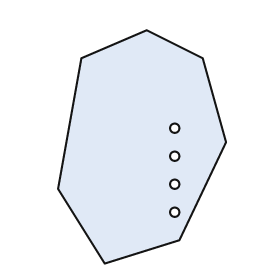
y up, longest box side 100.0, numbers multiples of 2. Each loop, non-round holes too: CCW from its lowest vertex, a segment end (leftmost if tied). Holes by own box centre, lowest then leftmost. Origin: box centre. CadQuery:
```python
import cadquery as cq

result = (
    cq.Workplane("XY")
    .moveTo(-16.0, -50.0)
    .lineTo(16.0, -40.0)
    .lineTo(36.0, 2.0)
    .lineTo(26.0, 38.0)
    .lineTo(2.0, 50.0)
    .lineTo(-26.0, 38.0)
    .lineTo(-36.0, -18.0)
    .close()
    .moveTo(14.0, -28.0)
    .circle(2.0)
    .moveTo(14.0, -16.0)
    .circle(2.0)
    .moveTo(14.0, -4.0)
    .circle(2.0)
    .moveTo(14.0, 8.0)
    .circle(2.0)
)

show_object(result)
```